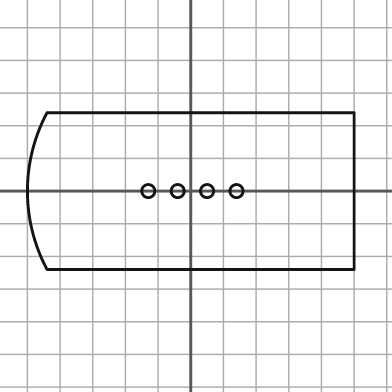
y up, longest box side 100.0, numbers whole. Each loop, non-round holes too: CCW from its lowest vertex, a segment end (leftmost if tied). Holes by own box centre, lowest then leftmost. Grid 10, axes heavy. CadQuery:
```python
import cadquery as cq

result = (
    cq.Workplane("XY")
    .moveTo(-44.0, -24.0)
    .lineTo(50.0, -24.0)
    .lineTo(50.0, 24.0)
    .lineTo(-44.0, 24.0)
    .threePointArc((-50.0, 0.0), (-44.0, -24.0))
    .close()
    .moveTo(-13.0, 0.0)
    .circle(2.0)
    .moveTo(-4.0, 0.0)
    .circle(2.0)
    .moveTo(5.0, 0.0)
    .circle(2.0)
    .moveTo(14.0, 0.0)
    .circle(2.0)
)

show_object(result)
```